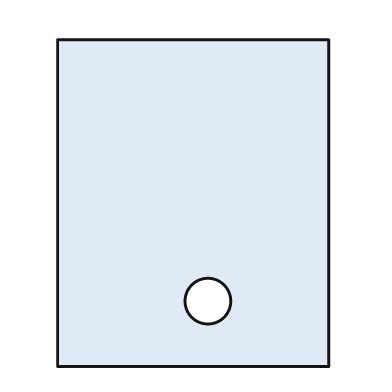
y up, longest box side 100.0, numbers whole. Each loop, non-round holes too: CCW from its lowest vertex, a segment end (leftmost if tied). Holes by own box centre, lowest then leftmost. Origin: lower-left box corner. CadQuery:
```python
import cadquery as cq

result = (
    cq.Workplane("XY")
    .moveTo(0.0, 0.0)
    .lineTo(83.0, 0.0)
    .lineTo(83.0, 100.0)
    .lineTo(0.0, 100.0)
    .close()
    .moveTo(46.0, 20.0)
    .circle(7.0)
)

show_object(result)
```